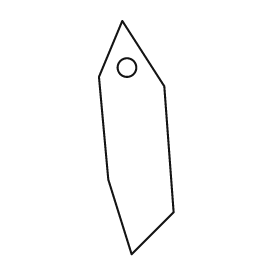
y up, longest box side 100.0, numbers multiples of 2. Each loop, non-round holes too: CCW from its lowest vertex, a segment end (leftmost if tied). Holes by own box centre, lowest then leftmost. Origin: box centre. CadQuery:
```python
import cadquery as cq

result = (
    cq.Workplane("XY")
    .moveTo(-2.0, -50.0)
    .lineTo(16.0, -32.0)
    .lineTo(12.0, 22.0)
    .lineTo(-6.0, 50.0)
    .lineTo(-16.0, 26.0)
    .lineTo(-12.0, -18.0)
    .close()
    .moveTo(-4.0, 30.0)
    .circle(4.0)
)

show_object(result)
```